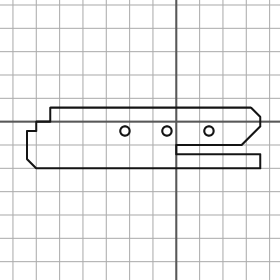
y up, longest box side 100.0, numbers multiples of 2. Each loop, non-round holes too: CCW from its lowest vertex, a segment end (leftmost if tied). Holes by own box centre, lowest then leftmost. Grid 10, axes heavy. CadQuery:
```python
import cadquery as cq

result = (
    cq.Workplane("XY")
    .moveTo(-60.0, -20.0)
    .lineTo(36.0, -20.0)
    .lineTo(36.0, -14.0)
    .lineTo(0.0, -14.0)
    .lineTo(0.0, -10.0)
    .lineTo(28.0, -10.0)
    .lineTo(36.0, -2.0)
    .lineTo(36.0, 2.0)
    .lineTo(32.0, 6.0)
    .lineTo(-54.0, 6.0)
    .lineTo(-54.0, 0.0)
    .lineTo(-60.0, 0.0)
    .lineTo(-60.0, -4.0)
    .lineTo(-64.0, -4.0)
    .lineTo(-64.0, -16.0)
    .close()
    .moveTo(-22.0, -4.0)
    .circle(2.0)
    .moveTo(-4.0, -4.0)
    .circle(2.0)
    .moveTo(14.0, -4.0)
    .circle(2.0)
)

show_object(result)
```